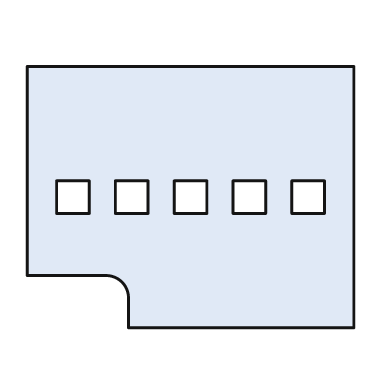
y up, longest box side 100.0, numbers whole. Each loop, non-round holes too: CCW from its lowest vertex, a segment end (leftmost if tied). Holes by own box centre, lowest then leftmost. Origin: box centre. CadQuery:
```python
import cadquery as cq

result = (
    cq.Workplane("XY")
    .moveTo(-19.0, -40.0)
    .lineTo(50.0, -40.0)
    .lineTo(50.0, 40.0)
    .lineTo(-50.0, 40.0)
    .lineTo(-50.0, -24.0)
    .lineTo(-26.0, -24.0)
    .threePointArc((-21.0, -26.0), (-19.0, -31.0))
    .close()
    .moveTo(-41.0, -5.0)
    .lineTo(-31.0, -5.0)
    .lineTo(-31.0, 5.0)
    .lineTo(-41.0, 5.0)
    .close()
    .moveTo(-23.0, -5.0)
    .lineTo(-13.0, -5.0)
    .lineTo(-13.0, 5.0)
    .lineTo(-23.0, 5.0)
    .close()
    .moveTo(-5.0, -5.0)
    .lineTo(5.0, -5.0)
    .lineTo(5.0, 5.0)
    .lineTo(-5.0, 5.0)
    .close()
    .moveTo(13.0, -5.0)
    .lineTo(23.0, -5.0)
    .lineTo(23.0, 5.0)
    .lineTo(13.0, 5.0)
    .close()
    .moveTo(31.0, -5.0)
    .lineTo(41.0, -5.0)
    .lineTo(41.0, 5.0)
    .lineTo(31.0, 5.0)
    .close()
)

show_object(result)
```